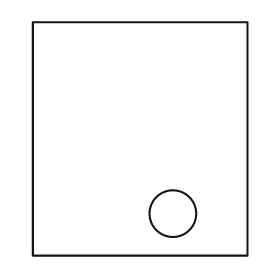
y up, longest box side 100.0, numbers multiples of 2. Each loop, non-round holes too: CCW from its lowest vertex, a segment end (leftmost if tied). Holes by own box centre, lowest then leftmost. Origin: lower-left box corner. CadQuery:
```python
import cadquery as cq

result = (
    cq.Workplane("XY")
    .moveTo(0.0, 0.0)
    .lineTo(92.0, 0.0)
    .lineTo(92.0, 100.0)
    .lineTo(0.0, 100.0)
    .close()
    .moveTo(60.0, 18.0)
    .circle(10.0)
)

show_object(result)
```